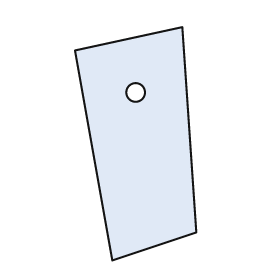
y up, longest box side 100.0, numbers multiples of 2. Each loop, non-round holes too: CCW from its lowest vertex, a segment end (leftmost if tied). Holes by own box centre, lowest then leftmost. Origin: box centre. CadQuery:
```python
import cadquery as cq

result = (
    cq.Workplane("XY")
    .moveTo(-10.0, -50.0)
    .lineTo(26.0, -38.0)
    .lineTo(20.0, 50.0)
    .lineTo(-26.0, 40.0)
    .close()
    .moveTo(0.0, 22.0)
    .circle(4.0)
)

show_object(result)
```